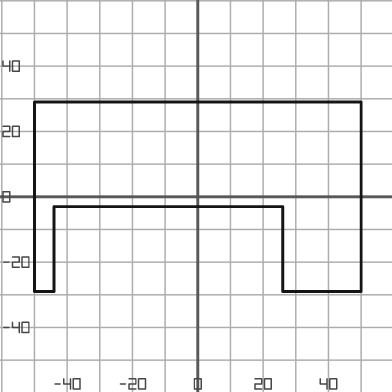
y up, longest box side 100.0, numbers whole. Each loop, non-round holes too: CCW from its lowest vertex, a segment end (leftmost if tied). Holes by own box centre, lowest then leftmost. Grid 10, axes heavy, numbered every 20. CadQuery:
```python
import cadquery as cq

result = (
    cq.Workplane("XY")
    .moveTo(-50.0, -29.0)
    .lineTo(-44.0, -29.0)
    .lineTo(-44.0, -3.0)
    .lineTo(26.0, -3.0)
    .lineTo(26.0, -29.0)
    .lineTo(50.0, -29.0)
    .lineTo(50.0, 29.0)
    .lineTo(-50.0, 29.0)
    .close()
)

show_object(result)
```